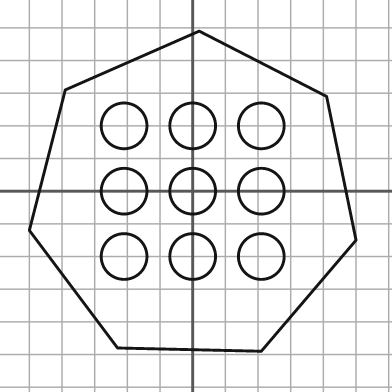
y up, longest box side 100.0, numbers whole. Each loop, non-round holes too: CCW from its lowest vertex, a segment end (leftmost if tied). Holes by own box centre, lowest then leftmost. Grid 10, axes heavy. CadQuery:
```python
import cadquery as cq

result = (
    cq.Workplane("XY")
    .moveTo(21.0, -49.0)
    .lineTo(50.0, -15.0)
    .lineTo(41.0, 29.0)
    .lineTo(2.0, 49.0)
    .lineTo(-39.0, 31.0)
    .lineTo(-50.0, -12.0)
    .lineTo(-23.0, -48.0)
    .close()
    .moveTo(-21.0, -20.0)
    .circle(7.0)
    .moveTo(0.0, -20.0)
    .circle(7.0)
    .moveTo(21.0, -20.0)
    .circle(7.0)
    .moveTo(-21.0, 0.0)
    .circle(7.0)
    .moveTo(0.0, 0.0)
    .circle(7.0)
    .moveTo(21.0, 0.0)
    .circle(7.0)
    .moveTo(-21.0, 20.0)
    .circle(7.0)
    .moveTo(0.0, 20.0)
    .circle(7.0)
    .moveTo(21.0, 20.0)
    .circle(7.0)
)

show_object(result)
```